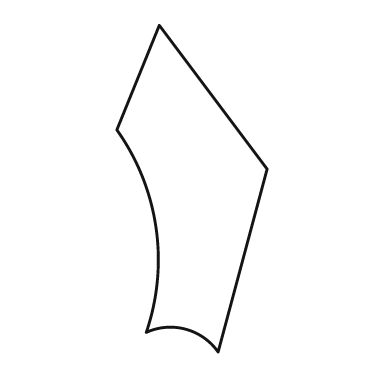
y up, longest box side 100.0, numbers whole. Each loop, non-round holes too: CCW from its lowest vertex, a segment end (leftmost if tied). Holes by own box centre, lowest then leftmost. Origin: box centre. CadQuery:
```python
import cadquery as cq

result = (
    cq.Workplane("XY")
    .moveTo(8.0, -50.0)
    .lineTo(23.0, 6.0)
    .lineTo(-10.0, 50.0)
    .lineTo(-23.0, 18.0)
    .threePointArc((-11.0, -12.0), (-14.0, -44.0))
    .threePointArc((-2.0, -43.0), (8.0, -50.0))
    .close()
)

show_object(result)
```